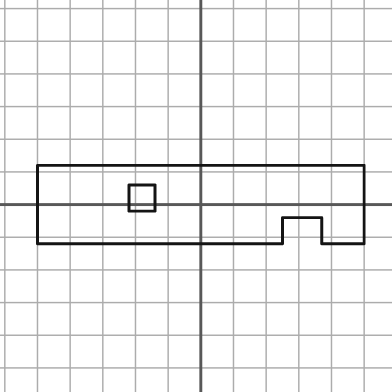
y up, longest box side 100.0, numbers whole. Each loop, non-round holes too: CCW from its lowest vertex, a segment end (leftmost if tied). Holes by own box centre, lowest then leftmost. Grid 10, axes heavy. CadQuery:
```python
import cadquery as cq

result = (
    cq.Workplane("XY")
    .moveTo(-50.0, -12.0)
    .lineTo(25.0, -12.0)
    .lineTo(25.0, -4.0)
    .lineTo(37.0, -4.0)
    .lineTo(37.0, -12.0)
    .lineTo(50.0, -12.0)
    .lineTo(50.0, 12.0)
    .lineTo(-50.0, 12.0)
    .close()
    .moveTo(-22.0, -2.0)
    .lineTo(-14.0, -2.0)
    .lineTo(-14.0, 6.0)
    .lineTo(-22.0, 6.0)
    .close()
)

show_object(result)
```